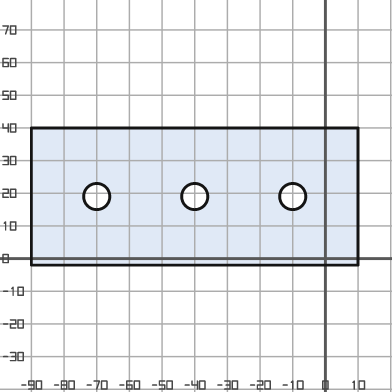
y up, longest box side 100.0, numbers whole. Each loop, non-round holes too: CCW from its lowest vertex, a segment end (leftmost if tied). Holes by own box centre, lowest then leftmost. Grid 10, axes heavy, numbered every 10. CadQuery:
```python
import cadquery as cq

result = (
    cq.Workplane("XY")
    .moveTo(-90.0, -2.0)
    .lineTo(10.0, -2.0)
    .lineTo(10.0, 40.0)
    .lineTo(-90.0, 40.0)
    .close()
    .moveTo(-70.0, 19.0)
    .circle(4.0)
    .moveTo(-40.0, 19.0)
    .circle(4.0)
    .moveTo(-10.0, 19.0)
    .circle(4.0)
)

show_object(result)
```